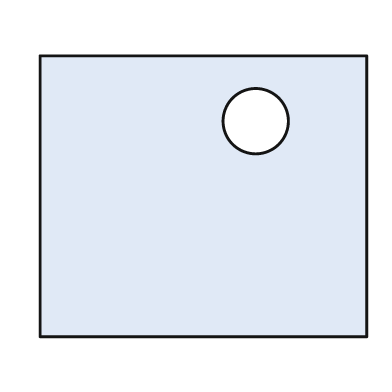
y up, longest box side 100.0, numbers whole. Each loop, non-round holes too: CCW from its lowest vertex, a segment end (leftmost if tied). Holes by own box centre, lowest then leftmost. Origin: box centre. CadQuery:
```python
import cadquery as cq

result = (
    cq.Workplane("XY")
    .moveTo(-50.0, -43.0)
    .lineTo(50.0, -43.0)
    .lineTo(50.0, 43.0)
    .lineTo(-50.0, 43.0)
    .close()
    .moveTo(16.0, 23.0)
    .circle(10.0)
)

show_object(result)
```